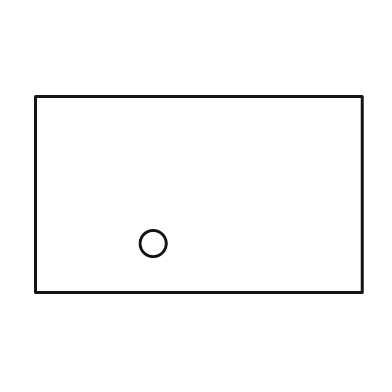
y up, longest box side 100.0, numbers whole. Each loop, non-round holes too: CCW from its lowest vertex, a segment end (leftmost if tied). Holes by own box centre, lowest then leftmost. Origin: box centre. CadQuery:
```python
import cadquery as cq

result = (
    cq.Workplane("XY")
    .moveTo(-50.0, -30.0)
    .lineTo(50.0, -30.0)
    .lineTo(50.0, 30.0)
    .lineTo(-50.0, 30.0)
    .close()
    .moveTo(-14.0, -15.0)
    .circle(4.0)
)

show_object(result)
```